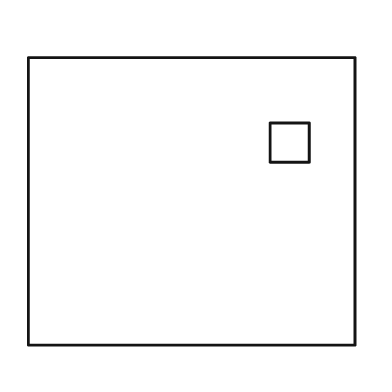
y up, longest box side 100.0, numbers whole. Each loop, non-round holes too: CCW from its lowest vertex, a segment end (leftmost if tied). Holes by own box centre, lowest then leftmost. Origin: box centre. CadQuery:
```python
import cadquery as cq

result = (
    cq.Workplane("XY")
    .moveTo(-50.0, -44.0)
    .lineTo(50.0, -44.0)
    .lineTo(50.0, 44.0)
    .lineTo(-50.0, 44.0)
    .close()
    .moveTo(24.0, 12.0)
    .lineTo(36.0, 12.0)
    .lineTo(36.0, 24.0)
    .lineTo(24.0, 24.0)
    .close()
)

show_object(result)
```